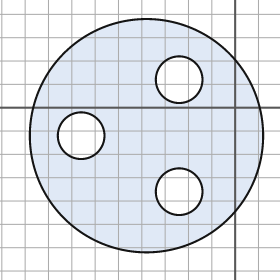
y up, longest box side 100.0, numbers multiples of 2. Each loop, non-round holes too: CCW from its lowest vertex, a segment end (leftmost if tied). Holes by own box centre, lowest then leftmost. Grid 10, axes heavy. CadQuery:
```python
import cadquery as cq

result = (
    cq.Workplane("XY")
    .moveTo(-38.0, -12.0)
    .circle(50.0)
    .moveTo(-24.0, -36.0)
    .circle(10.0)
    .moveTo(-66.0, -12.0)
    .circle(10.0)
    .moveTo(-24.0, 12.0)
    .circle(10.0)
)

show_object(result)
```